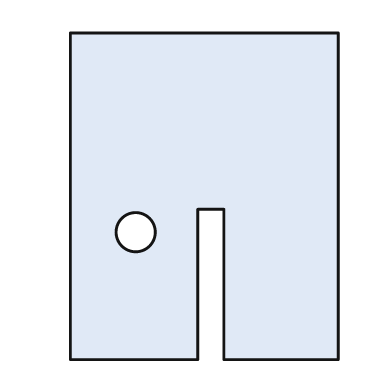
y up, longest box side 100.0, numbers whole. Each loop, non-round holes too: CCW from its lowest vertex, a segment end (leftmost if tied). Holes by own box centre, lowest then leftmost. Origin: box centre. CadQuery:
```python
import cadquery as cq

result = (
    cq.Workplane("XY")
    .moveTo(-41.0, -50.0)
    .lineTo(-2.0, -50.0)
    .lineTo(-2.0, -4.0)
    .lineTo(6.0, -4.0)
    .lineTo(6.0, -50.0)
    .lineTo(41.0, -50.0)
    .lineTo(41.0, 50.0)
    .lineTo(-41.0, 50.0)
    .close()
    .moveTo(-21.0, -11.0)
    .circle(6.0)
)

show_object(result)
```